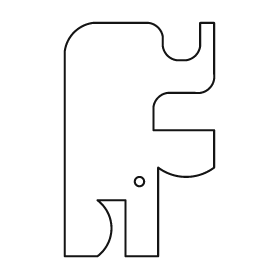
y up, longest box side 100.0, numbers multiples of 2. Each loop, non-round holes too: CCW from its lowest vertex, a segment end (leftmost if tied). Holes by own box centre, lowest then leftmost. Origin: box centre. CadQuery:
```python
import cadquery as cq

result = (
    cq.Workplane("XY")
    .moveTo(-32.0, -50.0)
    .lineTo(-18.0, -50.0)
    .threePointArc((-12.0, -38.0), (-18.0, -26.0))
    .lineTo(-6.0, -26.0)
    .lineTo(-6.0, -50.0)
    .lineTo(8.0, -50.0)
    .lineTo(8.0, -12.0)
    .threePointArc((20.0, -16.0), (32.0, -12.0))
    .lineTo(32.0, 4.0)
    .lineTo(6.0, 4.0)
    .lineTo(6.0, 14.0)
    .threePointArc((8.0, 18.0), (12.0, 20.0))
    .lineTo(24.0, 20.0)
    .threePointArc((30.0, 22.0), (32.0, 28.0))
    .lineTo(32.0, 50.0)
    .lineTo(26.0, 50.0)
    .lineTo(26.0, 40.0)
    .threePointArc((24.0, 36.0), (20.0, 34.0))
    .lineTo(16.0, 34.0)
    .threePointArc((12.0, 36.0), (10.0, 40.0))
    .lineTo(10.0, 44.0)
    .threePointArc((8.0, 48.0), (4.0, 50.0))
    .lineTo(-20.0, 50.0)
    .threePointArc((-28.0, 46.0), (-32.0, 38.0))
    .close()
    .moveTo(0.0, -18.0)
    .circle(2.0)
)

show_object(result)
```